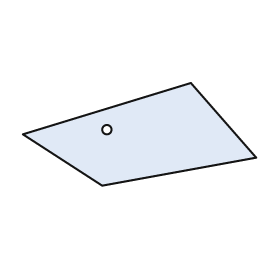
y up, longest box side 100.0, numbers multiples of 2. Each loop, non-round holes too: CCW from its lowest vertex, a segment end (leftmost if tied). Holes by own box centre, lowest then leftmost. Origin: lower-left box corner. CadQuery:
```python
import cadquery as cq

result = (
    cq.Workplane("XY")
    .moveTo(34.0, 0.0)
    .lineTo(100.0, 12.0)
    .lineTo(72.0, 44.0)
    .lineTo(0.0, 22.0)
    .close()
    .moveTo(36.0, 24.0)
    .circle(2.0)
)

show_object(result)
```